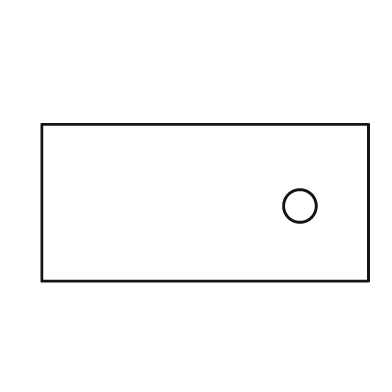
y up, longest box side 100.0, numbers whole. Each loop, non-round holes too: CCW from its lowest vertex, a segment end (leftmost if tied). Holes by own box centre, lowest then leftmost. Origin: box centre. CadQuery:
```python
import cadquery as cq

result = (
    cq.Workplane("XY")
    .moveTo(-50.0, -24.0)
    .lineTo(50.0, -24.0)
    .lineTo(50.0, 24.0)
    .lineTo(-50.0, 24.0)
    .close()
    .moveTo(29.0, -1.0)
    .circle(5.0)
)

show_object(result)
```